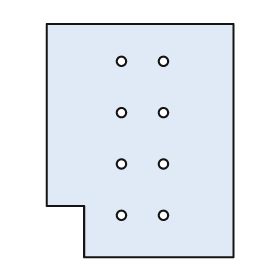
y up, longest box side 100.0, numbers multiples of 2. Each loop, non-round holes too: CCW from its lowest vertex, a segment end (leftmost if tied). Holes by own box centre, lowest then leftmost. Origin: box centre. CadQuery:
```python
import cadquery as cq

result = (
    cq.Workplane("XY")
    .moveTo(-24.0, -50.0)
    .lineTo(40.0, -50.0)
    .lineTo(40.0, 50.0)
    .lineTo(-40.0, 50.0)
    .lineTo(-40.0, -28.0)
    .lineTo(-24.0, -28.0)
    .close()
    .moveTo(-8.0, -32.0)
    .circle(2.0)
    .moveTo(10.0, -32.0)
    .circle(2.0)
    .moveTo(-8.0, -10.0)
    .circle(2.0)
    .moveTo(10.0, -10.0)
    .circle(2.0)
    .moveTo(-8.0, 12.0)
    .circle(2.0)
    .moveTo(10.0, 12.0)
    .circle(2.0)
    .moveTo(-8.0, 34.0)
    .circle(2.0)
    .moveTo(10.0, 34.0)
    .circle(2.0)
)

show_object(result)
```